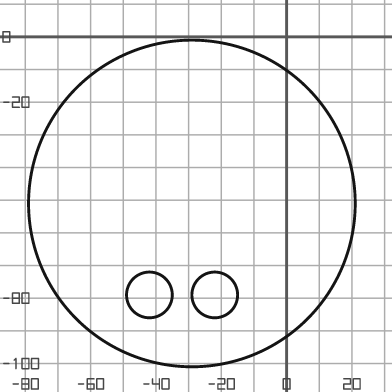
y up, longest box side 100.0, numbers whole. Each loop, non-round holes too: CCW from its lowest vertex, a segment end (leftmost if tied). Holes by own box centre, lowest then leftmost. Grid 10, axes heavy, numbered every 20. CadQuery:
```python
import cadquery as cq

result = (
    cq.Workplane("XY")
    .moveTo(-29.0, -51.0)
    .circle(50.0)
    .moveTo(-42.0, -79.0)
    .circle(7.0)
    .moveTo(-22.0, -79.0)
    .circle(7.0)
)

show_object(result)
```